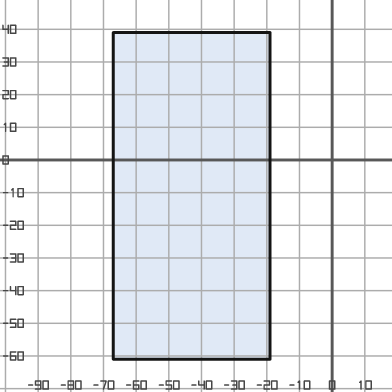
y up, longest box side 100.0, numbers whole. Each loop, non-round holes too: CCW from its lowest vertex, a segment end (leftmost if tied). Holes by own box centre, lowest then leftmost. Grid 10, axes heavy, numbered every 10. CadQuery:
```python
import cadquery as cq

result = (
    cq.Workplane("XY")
    .moveTo(-67.0, -61.0)
    .lineTo(-19.0, -61.0)
    .lineTo(-19.0, 39.0)
    .lineTo(-67.0, 39.0)
    .close()
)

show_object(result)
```